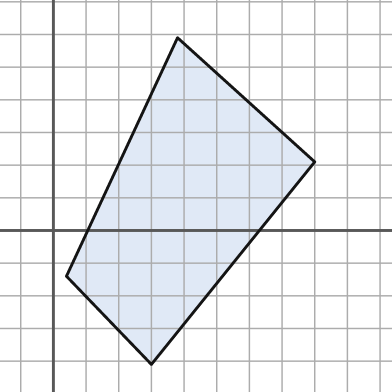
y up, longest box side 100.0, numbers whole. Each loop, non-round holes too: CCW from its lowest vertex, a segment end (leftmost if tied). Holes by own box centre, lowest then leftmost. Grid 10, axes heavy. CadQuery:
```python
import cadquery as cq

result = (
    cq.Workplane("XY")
    .moveTo(30.0, -41.0)
    .lineTo(80.0, 21.0)
    .lineTo(38.0, 59.0)
    .lineTo(4.0, -14.0)
    .close()
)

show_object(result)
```